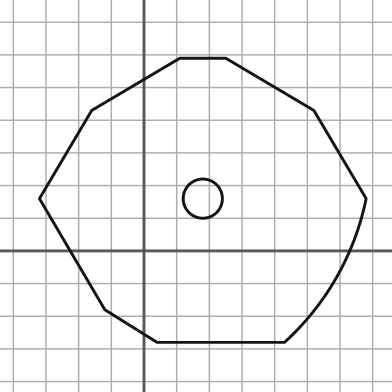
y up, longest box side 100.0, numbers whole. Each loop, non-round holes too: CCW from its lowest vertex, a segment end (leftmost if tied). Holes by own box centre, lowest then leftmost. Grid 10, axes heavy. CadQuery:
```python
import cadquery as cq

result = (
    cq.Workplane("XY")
    .moveTo(4.0, -28.0)
    .lineTo(43.0, -28.0)
    .threePointArc((59.0, -8.0), (68.0, 16.0))
    .lineTo(52.0, 43.0)
    .lineTo(25.0, 59.0)
    .lineTo(11.0, 59.0)
    .lineTo(-16.0, 43.0)
    .lineTo(-32.0, 16.0)
    .lineTo(-12.0, -18.0)
    .close()
    .moveTo(18.0, 16.0)
    .circle(6.0)
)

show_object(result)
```